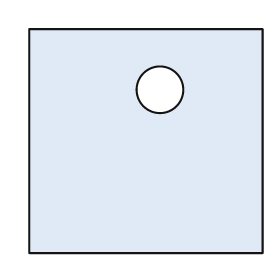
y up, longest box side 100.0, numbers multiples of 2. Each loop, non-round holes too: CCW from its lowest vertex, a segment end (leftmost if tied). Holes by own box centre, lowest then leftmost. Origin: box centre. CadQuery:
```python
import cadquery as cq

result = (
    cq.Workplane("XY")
    .moveTo(-50.0, -48.0)
    .lineTo(50.0, -48.0)
    .lineTo(50.0, 48.0)
    .lineTo(-50.0, 48.0)
    .close()
    .moveTo(6.0, 22.0)
    .circle(10.0)
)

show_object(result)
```